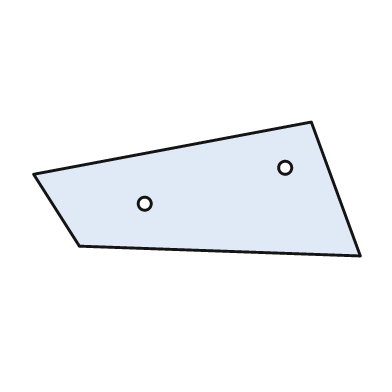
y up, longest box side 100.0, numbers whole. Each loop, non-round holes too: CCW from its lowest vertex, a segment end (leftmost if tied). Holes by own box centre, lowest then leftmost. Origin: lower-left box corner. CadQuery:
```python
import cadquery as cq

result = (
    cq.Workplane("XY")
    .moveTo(100.0, 0.0)
    .lineTo(85.0, 41.0)
    .lineTo(0.0, 25.0)
    .lineTo(14.0, 3.0)
    .close()
    .moveTo(34.0, 16.0)
    .circle(2.0)
    .moveTo(77.0, 27.0)
    .circle(2.0)
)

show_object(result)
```